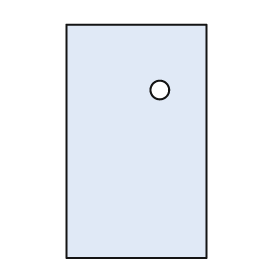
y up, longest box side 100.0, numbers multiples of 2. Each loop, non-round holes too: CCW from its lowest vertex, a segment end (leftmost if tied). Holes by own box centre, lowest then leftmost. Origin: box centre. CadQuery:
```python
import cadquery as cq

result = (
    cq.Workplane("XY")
    .moveTo(-30.0, -50.0)
    .lineTo(30.0, -50.0)
    .lineTo(30.0, 50.0)
    .lineTo(-30.0, 50.0)
    .close()
    .moveTo(10.0, 22.0)
    .circle(4.0)
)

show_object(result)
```